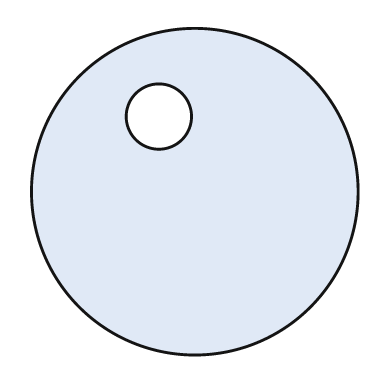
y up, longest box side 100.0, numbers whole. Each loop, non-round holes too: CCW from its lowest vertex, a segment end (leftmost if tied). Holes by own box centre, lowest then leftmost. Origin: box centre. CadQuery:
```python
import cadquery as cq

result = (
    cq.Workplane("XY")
    .moveTo(0.0, 0.0)
    .circle(50.0)
    .moveTo(-11.0, 23.0)
    .circle(10.0)
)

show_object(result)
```